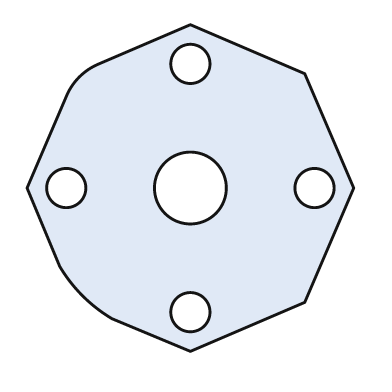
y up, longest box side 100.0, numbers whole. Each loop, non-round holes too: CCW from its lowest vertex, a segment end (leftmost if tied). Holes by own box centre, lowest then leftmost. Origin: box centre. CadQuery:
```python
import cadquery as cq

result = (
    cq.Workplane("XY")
    .moveTo(0.0, -50.0)
    .lineTo(35.0, -35.0)
    .lineTo(50.0, 0.0)
    .lineTo(35.0, 35.0)
    .lineTo(0.0, 50.0)
    .lineTo(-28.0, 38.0)
    .threePointArc((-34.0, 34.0), (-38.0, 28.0))
    .lineTo(-50.0, 0.0)
    .lineTo(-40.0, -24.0)
    .threePointArc((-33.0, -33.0), (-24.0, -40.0))
    .close()
    .moveTo(0.0, -38.0)
    .circle(6.0)
    .moveTo(-38.0, 0.0)
    .circle(6.0)
    .moveTo(0.0, 0.0)
    .circle(11.0)
    .moveTo(38.0, 0.0)
    .circle(6.0)
    .moveTo(0.0, 38.0)
    .circle(6.0)
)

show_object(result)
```